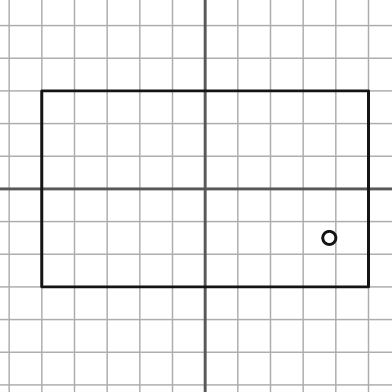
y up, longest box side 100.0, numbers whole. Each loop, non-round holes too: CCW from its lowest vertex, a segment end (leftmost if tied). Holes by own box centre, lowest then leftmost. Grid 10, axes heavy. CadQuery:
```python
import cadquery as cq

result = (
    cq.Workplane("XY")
    .moveTo(-50.0, -30.0)
    .lineTo(50.0, -30.0)
    .lineTo(50.0, 30.0)
    .lineTo(-50.0, 30.0)
    .close()
    .moveTo(38.0, -15.0)
    .circle(2.0)
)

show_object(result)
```